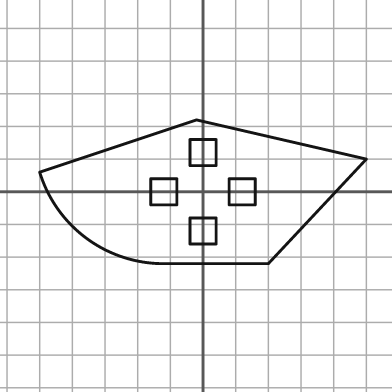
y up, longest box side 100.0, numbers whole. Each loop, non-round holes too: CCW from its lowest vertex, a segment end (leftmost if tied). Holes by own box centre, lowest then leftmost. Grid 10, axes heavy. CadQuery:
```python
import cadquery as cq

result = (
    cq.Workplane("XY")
    .moveTo(-13.0, -22.0)
    .lineTo(20.0, -22.0)
    .lineTo(50.0, 10.0)
    .lineTo(-2.0, 22.0)
    .lineTo(-50.0, 6.0)
    .threePointArc((-36.0, -14.0), (-13.0, -22.0))
    .close()
    .moveTo(-4.0, -16.0)
    .lineTo(4.0, -16.0)
    .lineTo(4.0, -8.0)
    .lineTo(-4.0, -8.0)
    .close()
    .moveTo(-16.0, -4.0)
    .lineTo(-8.0, -4.0)
    .lineTo(-8.0, 4.0)
    .lineTo(-16.0, 4.0)
    .close()
    .moveTo(8.0, -4.0)
    .lineTo(16.0, -4.0)
    .lineTo(16.0, 4.0)
    .lineTo(8.0, 4.0)
    .close()
    .moveTo(-4.0, 8.0)
    .lineTo(4.0, 8.0)
    .lineTo(4.0, 16.0)
    .lineTo(-4.0, 16.0)
    .close()
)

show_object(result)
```